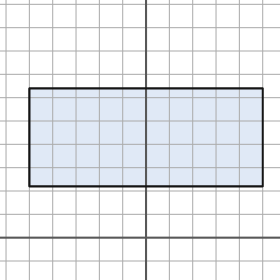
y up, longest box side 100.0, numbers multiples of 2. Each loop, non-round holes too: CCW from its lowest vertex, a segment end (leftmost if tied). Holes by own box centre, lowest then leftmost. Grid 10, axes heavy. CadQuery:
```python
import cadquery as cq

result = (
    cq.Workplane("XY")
    .moveTo(-50.0, 22.0)
    .lineTo(50.0, 22.0)
    .lineTo(50.0, 64.0)
    .lineTo(-50.0, 64.0)
    .close()
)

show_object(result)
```